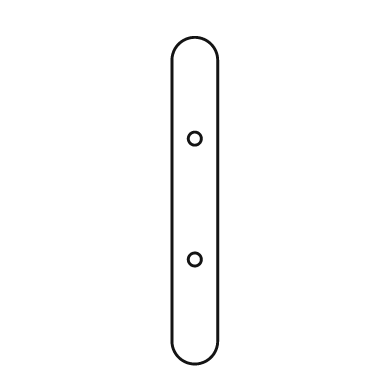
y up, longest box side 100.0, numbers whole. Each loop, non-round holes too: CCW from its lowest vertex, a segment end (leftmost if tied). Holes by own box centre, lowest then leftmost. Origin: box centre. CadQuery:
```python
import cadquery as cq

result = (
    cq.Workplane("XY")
    .moveTo(-7.0, -43.0)
    .threePointArc((0.0, -50.0), (7.0, -43.0))
    .lineTo(7.0, 43.0)
    .threePointArc((0.0, 50.0), (-7.0, 43.0))
    .close()
    .moveTo(0.0, -18.0)
    .circle(2.0)
    .moveTo(0.0, 19.0)
    .circle(2.0)
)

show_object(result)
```